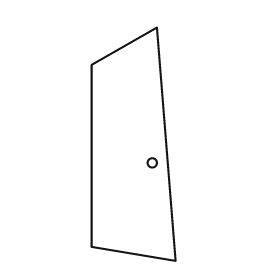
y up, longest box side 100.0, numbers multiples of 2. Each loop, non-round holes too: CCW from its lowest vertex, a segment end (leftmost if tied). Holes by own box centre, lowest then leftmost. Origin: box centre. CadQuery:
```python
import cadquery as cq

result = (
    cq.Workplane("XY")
    .moveTo(18.0, -50.0)
    .lineTo(10.0, 50.0)
    .lineTo(-18.0, 34.0)
    .lineTo(-18.0, -44.0)
    .close()
    .moveTo(8.0, -8.0)
    .circle(2.0)
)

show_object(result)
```